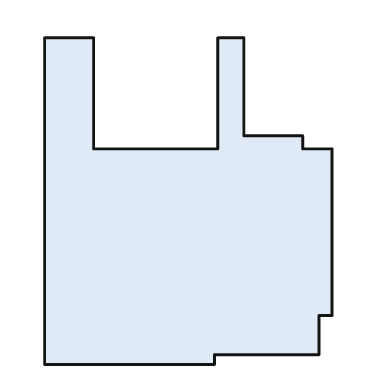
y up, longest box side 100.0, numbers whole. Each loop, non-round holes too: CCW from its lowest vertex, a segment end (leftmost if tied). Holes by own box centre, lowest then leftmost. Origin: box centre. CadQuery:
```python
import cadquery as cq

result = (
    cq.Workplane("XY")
    .moveTo(-44.0, -50.0)
    .lineTo(8.0, -50.0)
    .lineTo(8.0, -47.0)
    .lineTo(40.0, -47.0)
    .lineTo(40.0, -35.0)
    .lineTo(44.0, -35.0)
    .lineTo(44.0, 16.0)
    .lineTo(35.0, 16.0)
    .lineTo(35.0, 20.0)
    .lineTo(17.0, 20.0)
    .lineTo(17.0, 50.0)
    .lineTo(9.0, 50.0)
    .lineTo(9.0, 16.0)
    .lineTo(-29.0, 16.0)
    .lineTo(-29.0, 50.0)
    .lineTo(-44.0, 50.0)
    .close()
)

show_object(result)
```